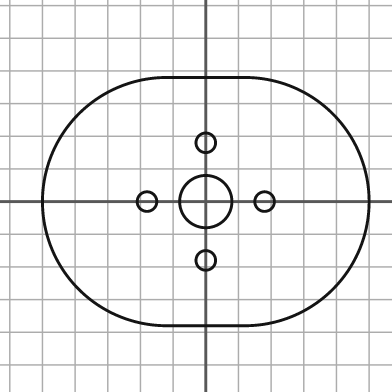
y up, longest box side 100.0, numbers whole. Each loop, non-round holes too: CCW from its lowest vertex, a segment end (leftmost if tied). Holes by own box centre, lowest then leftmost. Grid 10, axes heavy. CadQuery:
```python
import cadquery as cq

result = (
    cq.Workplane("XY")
    .moveTo(-12.0, -38.0)
    .lineTo(12.0, -38.0)
    .threePointArc((50.0, 0.0), (12.0, 38.0))
    .lineTo(-12.0, 38.0)
    .threePointArc((-50.0, 0.0), (-12.0, -38.0))
    .close()
    .moveTo(0.0, -18.0)
    .circle(3.0)
    .moveTo(-18.0, 0.0)
    .circle(3.0)
    .moveTo(0.0, 0.0)
    .circle(8.0)
    .moveTo(18.0, 0.0)
    .circle(3.0)
    .moveTo(0.0, 18.0)
    .circle(3.0)
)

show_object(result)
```